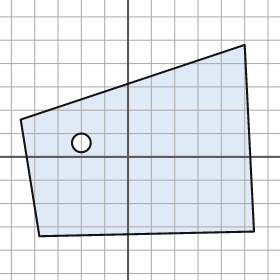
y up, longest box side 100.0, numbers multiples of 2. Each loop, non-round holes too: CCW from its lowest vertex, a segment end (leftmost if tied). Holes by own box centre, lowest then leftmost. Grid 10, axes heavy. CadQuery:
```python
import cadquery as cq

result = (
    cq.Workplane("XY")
    .moveTo(-38.0, -34.0)
    .lineTo(54.0, -32.0)
    .lineTo(50.0, 48.0)
    .lineTo(-46.0, 16.0)
    .close()
    .moveTo(-20.0, 6.0)
    .circle(4.0)
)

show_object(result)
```